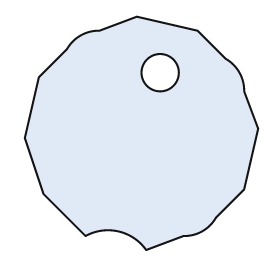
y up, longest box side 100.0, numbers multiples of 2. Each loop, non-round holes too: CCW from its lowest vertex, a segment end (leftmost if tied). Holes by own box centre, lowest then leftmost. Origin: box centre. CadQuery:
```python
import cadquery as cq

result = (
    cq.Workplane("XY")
    .moveTo(2.0, -50.0)
    .lineTo(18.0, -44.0)
    .threePointArc((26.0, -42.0), (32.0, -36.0))
    .lineTo(44.0, -24.0)
    .lineTo(50.0, 2.0)
    .lineTo(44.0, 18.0)
    .threePointArc((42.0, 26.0), (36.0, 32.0))
    .lineTo(24.0, 44.0)
    .lineTo(-2.0, 50.0)
    .lineTo(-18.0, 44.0)
    .threePointArc((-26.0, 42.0), (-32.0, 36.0))
    .lineTo(-44.0, 24.0)
    .lineTo(-50.0, -2.0)
    .lineTo(-42.0, -26.0)
    .lineTo(-24.0, -44.0)
    .threePointArc((-10.0, -42.0), (2.0, -50.0))
    .close()
    .moveTo(8.0, 26.0)
    .circle(8.0)
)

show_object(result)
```